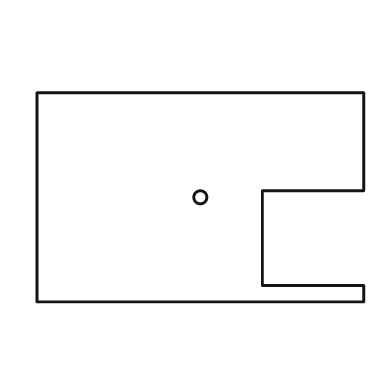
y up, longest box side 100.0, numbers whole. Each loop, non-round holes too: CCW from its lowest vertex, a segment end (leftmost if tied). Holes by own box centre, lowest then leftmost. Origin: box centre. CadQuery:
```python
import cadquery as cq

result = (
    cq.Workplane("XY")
    .moveTo(-50.0, -32.0)
    .lineTo(50.0, -32.0)
    .lineTo(50.0, -27.0)
    .lineTo(19.0, -27.0)
    .lineTo(19.0, 2.0)
    .lineTo(50.0, 2.0)
    .lineTo(50.0, 32.0)
    .lineTo(-50.0, 32.0)
    .close()
    .moveTo(0.0, 0.0)
    .circle(2.0)
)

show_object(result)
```